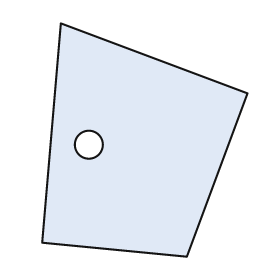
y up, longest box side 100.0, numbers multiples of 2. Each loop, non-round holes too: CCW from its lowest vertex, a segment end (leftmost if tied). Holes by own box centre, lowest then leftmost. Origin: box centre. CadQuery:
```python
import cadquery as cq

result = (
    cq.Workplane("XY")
    .moveTo(18.0, -50.0)
    .lineTo(44.0, 20.0)
    .lineTo(-36.0, 50.0)
    .lineTo(-44.0, -44.0)
    .close()
    .moveTo(-24.0, -2.0)
    .circle(6.0)
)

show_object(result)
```